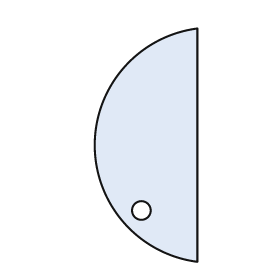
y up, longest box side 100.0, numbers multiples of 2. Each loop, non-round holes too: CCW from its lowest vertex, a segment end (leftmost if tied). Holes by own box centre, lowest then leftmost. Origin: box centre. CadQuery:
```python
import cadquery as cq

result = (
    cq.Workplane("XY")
    .moveTo(22.0, -50.0)
    .lineTo(22.0, 50.0)
    .threePointArc((-22.0, 0.0), (22.0, -50.0))
    .close()
    .moveTo(-2.0, -28.0)
    .circle(4.0)
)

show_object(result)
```